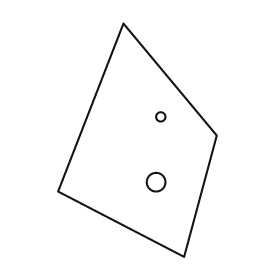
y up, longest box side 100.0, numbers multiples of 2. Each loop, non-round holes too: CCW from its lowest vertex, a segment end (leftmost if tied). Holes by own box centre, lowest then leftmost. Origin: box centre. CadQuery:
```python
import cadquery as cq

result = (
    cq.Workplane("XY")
    .moveTo(20.0, -50.0)
    .lineTo(34.0, 2.0)
    .lineTo(-6.0, 50.0)
    .lineTo(-34.0, -22.0)
    .close()
    .moveTo(8.0, -18.0)
    .circle(4.0)
    .moveTo(10.0, 10.0)
    .circle(2.0)
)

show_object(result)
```